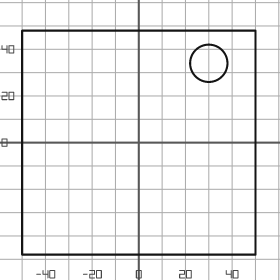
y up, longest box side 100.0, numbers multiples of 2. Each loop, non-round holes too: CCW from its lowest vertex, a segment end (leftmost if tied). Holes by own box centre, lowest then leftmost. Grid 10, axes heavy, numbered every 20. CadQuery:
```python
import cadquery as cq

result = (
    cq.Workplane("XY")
    .moveTo(-50.0, -48.0)
    .lineTo(50.0, -48.0)
    .lineTo(50.0, 48.0)
    .lineTo(-50.0, 48.0)
    .close()
    .moveTo(30.0, 34.0)
    .circle(8.0)
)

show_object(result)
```